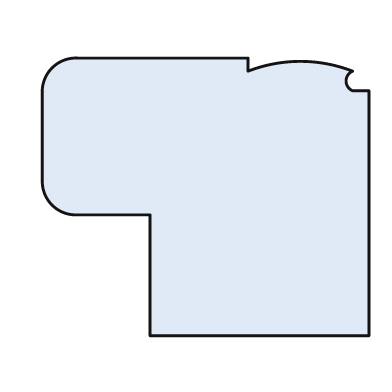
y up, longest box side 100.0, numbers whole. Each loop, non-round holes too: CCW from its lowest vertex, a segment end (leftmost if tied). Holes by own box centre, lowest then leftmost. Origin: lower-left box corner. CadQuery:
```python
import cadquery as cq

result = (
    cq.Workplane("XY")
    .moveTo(33.0, 0.0)
    .lineTo(100.0, 0.0)
    .lineTo(100.0, 75.0)
    .lineTo(95.0, 75.0)
    .threePointArc((93.0, 78.0), (95.0, 81.0))
    .threePointArc((79.0, 84.0), (63.0, 81.0))
    .lineTo(63.0, 85.0)
    .lineTo(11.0, 85.0)
    .threePointArc((3.0, 82.0), (0.0, 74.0))
    .lineTo(0.0, 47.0)
    .threePointArc((3.0, 40.0), (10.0, 37.0))
    .lineTo(33.0, 37.0)
    .close()
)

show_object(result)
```